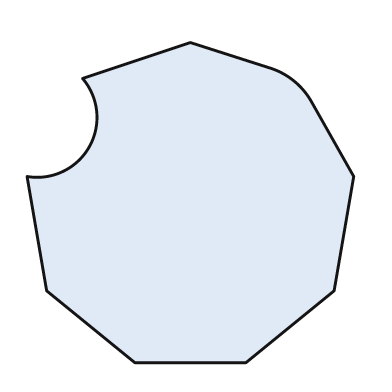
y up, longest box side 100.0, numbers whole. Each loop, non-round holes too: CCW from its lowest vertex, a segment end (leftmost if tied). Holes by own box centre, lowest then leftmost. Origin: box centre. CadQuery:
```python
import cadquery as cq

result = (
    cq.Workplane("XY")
    .moveTo(-17.0, -49.0)
    .lineTo(17.0, -49.0)
    .lineTo(44.0, -27.0)
    .lineTo(50.0, 8.0)
    .lineTo(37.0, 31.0)
    .threePointArc((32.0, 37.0), (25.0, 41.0))
    .lineTo(0.0, 49.0)
    .lineTo(-33.0, 38.0)
    .threePointArc((-31.0, 17.0), (-50.0, 8.0))
    .lineTo(-44.0, -27.0)
    .close()
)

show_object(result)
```